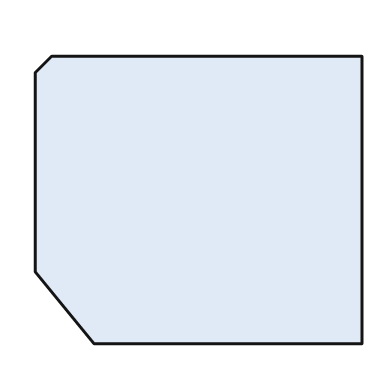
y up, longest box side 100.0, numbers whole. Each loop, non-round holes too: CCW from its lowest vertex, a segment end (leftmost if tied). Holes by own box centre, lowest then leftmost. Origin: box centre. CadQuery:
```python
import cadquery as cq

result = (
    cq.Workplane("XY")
    .moveTo(-32.0, -44.0)
    .lineTo(50.0, -44.0)
    .lineTo(50.0, 44.0)
    .lineTo(-45.0, 44.0)
    .lineTo(-50.0, 39.0)
    .lineTo(-50.0, -22.0)
    .close()
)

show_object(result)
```